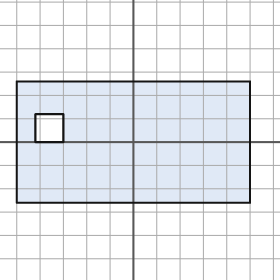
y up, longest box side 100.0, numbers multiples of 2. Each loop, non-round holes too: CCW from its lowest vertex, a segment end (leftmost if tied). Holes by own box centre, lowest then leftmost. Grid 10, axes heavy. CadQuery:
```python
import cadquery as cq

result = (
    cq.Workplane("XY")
    .moveTo(-50.0, -26.0)
    .lineTo(50.0, -26.0)
    .lineTo(50.0, 26.0)
    .lineTo(-50.0, 26.0)
    .close()
    .moveTo(-42.0, 0.0)
    .lineTo(-30.0, 0.0)
    .lineTo(-30.0, 12.0)
    .lineTo(-42.0, 12.0)
    .close()
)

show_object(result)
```